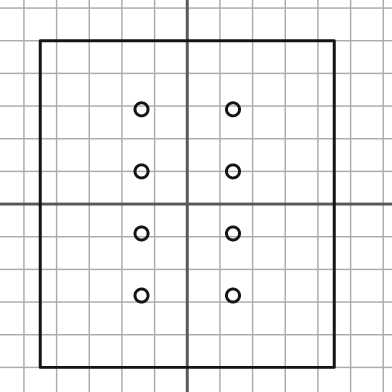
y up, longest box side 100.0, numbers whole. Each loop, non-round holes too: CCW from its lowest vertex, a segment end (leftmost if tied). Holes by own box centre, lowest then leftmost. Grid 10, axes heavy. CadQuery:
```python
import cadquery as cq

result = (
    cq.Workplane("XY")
    .moveTo(-45.0, -50.0)
    .lineTo(45.0, -50.0)
    .lineTo(45.0, 50.0)
    .lineTo(-45.0, 50.0)
    .close()
    .moveTo(-14.0, -28.0)
    .circle(2.0)
    .moveTo(14.0, -28.0)
    .circle(2.0)
    .moveTo(-14.0, -9.0)
    .circle(2.0)
    .moveTo(14.0, -9.0)
    .circle(2.0)
    .moveTo(-14.0, 10.0)
    .circle(2.0)
    .moveTo(14.0, 10.0)
    .circle(2.0)
    .moveTo(-14.0, 29.0)
    .circle(2.0)
    .moveTo(14.0, 29.0)
    .circle(2.0)
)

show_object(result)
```